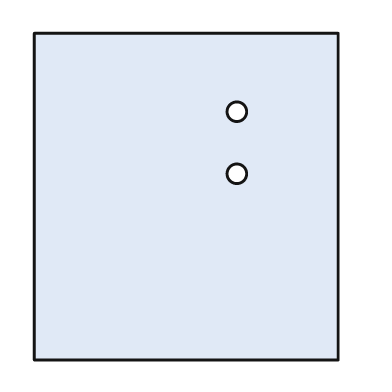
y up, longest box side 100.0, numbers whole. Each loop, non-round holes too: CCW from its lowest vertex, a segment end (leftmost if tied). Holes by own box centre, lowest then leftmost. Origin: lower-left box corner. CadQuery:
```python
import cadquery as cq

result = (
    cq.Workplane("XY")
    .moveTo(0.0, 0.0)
    .lineTo(93.0, 0.0)
    .lineTo(93.0, 100.0)
    .lineTo(0.0, 100.0)
    .close()
    .moveTo(62.0, 57.0)
    .circle(3.0)
    .moveTo(62.0, 76.0)
    .circle(3.0)
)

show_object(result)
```